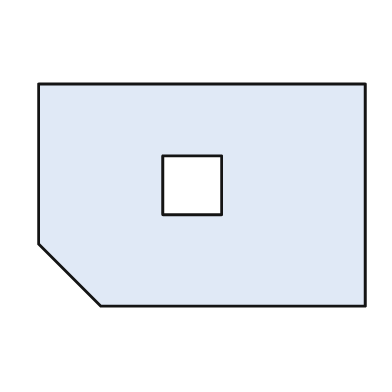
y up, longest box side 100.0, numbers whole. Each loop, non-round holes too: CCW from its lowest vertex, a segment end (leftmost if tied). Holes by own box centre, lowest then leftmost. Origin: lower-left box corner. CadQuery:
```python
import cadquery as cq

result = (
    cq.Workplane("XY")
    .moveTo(19.0, 0.0)
    .lineTo(100.0, 0.0)
    .lineTo(100.0, 68.0)
    .lineTo(0.0, 68.0)
    .lineTo(0.0, 19.0)
    .close()
    .moveTo(38.0, 28.0)
    .lineTo(56.0, 28.0)
    .lineTo(56.0, 46.0)
    .lineTo(38.0, 46.0)
    .close()
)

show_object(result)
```